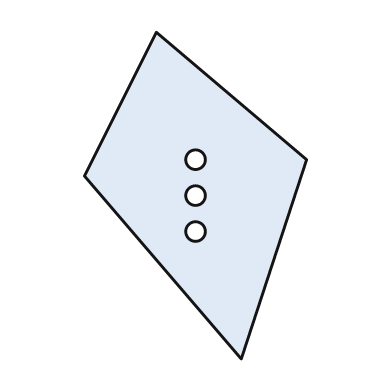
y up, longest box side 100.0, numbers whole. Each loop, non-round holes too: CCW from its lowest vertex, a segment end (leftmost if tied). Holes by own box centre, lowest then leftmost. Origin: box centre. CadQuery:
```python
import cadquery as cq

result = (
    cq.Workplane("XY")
    .moveTo(14.0, -50.0)
    .lineTo(34.0, 11.0)
    .lineTo(-12.0, 50.0)
    .lineTo(-34.0, 6.0)
    .close()
    .moveTo(0.0, -11.0)
    .circle(3.0)
    .moveTo(0.0, 0.0)
    .circle(3.0)
    .moveTo(0.0, 11.0)
    .circle(3.0)
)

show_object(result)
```